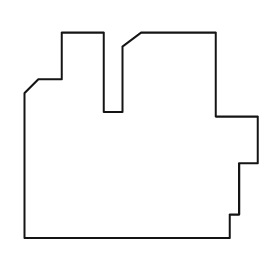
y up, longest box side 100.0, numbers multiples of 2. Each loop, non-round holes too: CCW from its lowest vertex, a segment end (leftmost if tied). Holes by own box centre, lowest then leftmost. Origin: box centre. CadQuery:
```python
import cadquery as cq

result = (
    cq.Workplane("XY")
    .moveTo(-50.0, -44.0)
    .lineTo(38.0, -44.0)
    .lineTo(38.0, -34.0)
    .lineTo(42.0, -34.0)
    .lineTo(42.0, -12.0)
    .lineTo(50.0, -12.0)
    .lineTo(50.0, 8.0)
    .lineTo(32.0, 8.0)
    .lineTo(32.0, 44.0)
    .lineTo(0.0, 44.0)
    .lineTo(-8.0, 38.0)
    .lineTo(-8.0, 10.0)
    .lineTo(-16.0, 10.0)
    .lineTo(-16.0, 44.0)
    .lineTo(-34.0, 44.0)
    .lineTo(-34.0, 24.0)
    .lineTo(-44.0, 24.0)
    .lineTo(-50.0, 18.0)
    .close()
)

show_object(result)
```